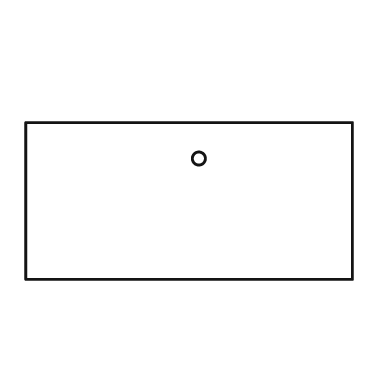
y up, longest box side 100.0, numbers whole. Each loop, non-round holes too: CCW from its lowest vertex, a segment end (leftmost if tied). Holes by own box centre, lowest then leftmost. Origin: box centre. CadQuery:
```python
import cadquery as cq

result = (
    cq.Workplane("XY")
    .moveTo(-50.0, -24.0)
    .lineTo(50.0, -24.0)
    .lineTo(50.0, 24.0)
    .lineTo(-50.0, 24.0)
    .close()
    .moveTo(3.0, 13.0)
    .circle(2.0)
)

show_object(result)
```